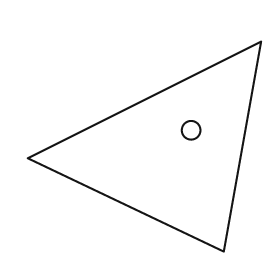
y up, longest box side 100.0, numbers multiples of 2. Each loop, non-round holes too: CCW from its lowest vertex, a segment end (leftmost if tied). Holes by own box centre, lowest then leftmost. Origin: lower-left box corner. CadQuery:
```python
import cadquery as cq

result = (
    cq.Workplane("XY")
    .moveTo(84.0, 0.0)
    .lineTo(100.0, 90.0)
    .lineTo(0.0, 40.0)
    .close()
    .moveTo(70.0, 52.0)
    .circle(4.0)
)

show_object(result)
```